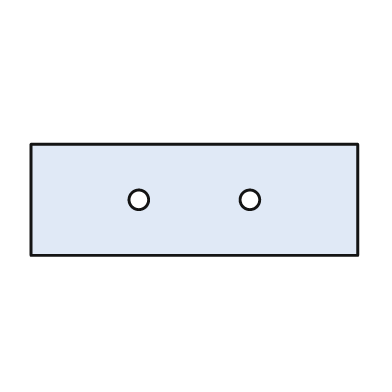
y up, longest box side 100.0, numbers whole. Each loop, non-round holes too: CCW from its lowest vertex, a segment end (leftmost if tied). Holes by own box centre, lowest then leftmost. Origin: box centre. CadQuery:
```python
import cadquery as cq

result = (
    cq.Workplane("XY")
    .moveTo(-50.0, -17.0)
    .lineTo(50.0, -17.0)
    .lineTo(50.0, 17.0)
    .lineTo(-50.0, 17.0)
    .close()
    .moveTo(-17.0, 0.0)
    .circle(3.0)
    .moveTo(17.0, 0.0)
    .circle(3.0)
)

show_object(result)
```